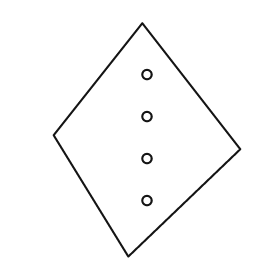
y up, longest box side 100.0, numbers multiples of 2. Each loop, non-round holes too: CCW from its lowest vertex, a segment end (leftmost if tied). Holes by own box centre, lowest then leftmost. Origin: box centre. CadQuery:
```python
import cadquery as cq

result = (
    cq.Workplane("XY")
    .moveTo(-8.0, -50.0)
    .lineTo(40.0, -4.0)
    .lineTo(-2.0, 50.0)
    .lineTo(-40.0, 2.0)
    .close()
    .moveTo(0.0, -26.0)
    .circle(2.0)
    .moveTo(0.0, -8.0)
    .circle(2.0)
    .moveTo(0.0, 10.0)
    .circle(2.0)
    .moveTo(0.0, 28.0)
    .circle(2.0)
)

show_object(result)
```